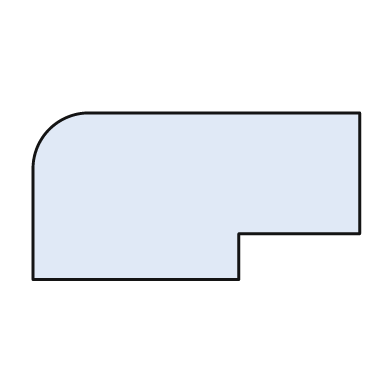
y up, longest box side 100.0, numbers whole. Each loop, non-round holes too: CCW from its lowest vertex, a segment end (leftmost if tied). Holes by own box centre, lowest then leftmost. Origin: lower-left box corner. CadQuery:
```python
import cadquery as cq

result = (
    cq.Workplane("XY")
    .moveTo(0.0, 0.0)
    .lineTo(63.0, 0.0)
    .lineTo(63.0, 14.0)
    .lineTo(100.0, 14.0)
    .lineTo(100.0, 51.0)
    .lineTo(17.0, 51.0)
    .threePointArc((5.0, 46.0), (0.0, 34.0))
    .close()
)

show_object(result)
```